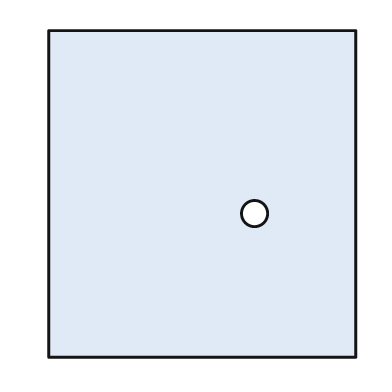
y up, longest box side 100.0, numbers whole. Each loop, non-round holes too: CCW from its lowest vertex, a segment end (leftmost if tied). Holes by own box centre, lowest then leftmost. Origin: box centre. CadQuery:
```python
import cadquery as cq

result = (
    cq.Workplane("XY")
    .moveTo(-47.0, -50.0)
    .lineTo(47.0, -50.0)
    .lineTo(47.0, 50.0)
    .lineTo(-47.0, 50.0)
    .close()
    .moveTo(16.0, -6.0)
    .circle(4.0)
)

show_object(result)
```